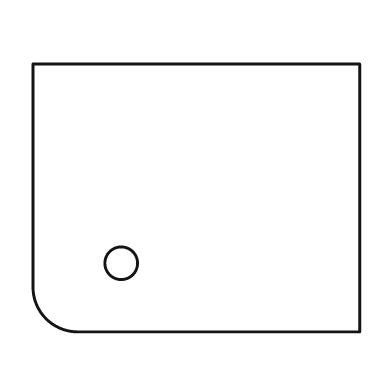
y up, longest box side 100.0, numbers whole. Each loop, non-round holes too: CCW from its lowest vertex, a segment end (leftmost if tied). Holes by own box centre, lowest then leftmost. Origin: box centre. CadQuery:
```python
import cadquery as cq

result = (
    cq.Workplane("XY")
    .moveTo(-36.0, -41.0)
    .lineTo(50.0, -41.0)
    .lineTo(50.0, 41.0)
    .lineTo(-50.0, 41.0)
    .lineTo(-50.0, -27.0)
    .threePointArc((-46.0, -37.0), (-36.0, -41.0))
    .close()
    .moveTo(-23.0, -20.0)
    .circle(5.0)
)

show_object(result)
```